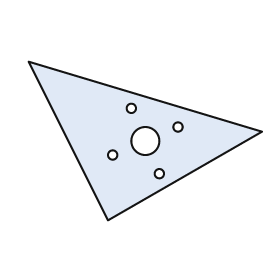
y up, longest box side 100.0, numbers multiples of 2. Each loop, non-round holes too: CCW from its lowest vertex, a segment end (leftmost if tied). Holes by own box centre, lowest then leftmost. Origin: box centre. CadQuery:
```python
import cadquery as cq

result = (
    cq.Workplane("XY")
    .moveTo(-16.0, -34.0)
    .lineTo(50.0, 4.0)
    .lineTo(-50.0, 34.0)
    .close()
    .moveTo(6.0, -14.0)
    .circle(2.0)
    .moveTo(-14.0, -6.0)
    .circle(2.0)
    .moveTo(0.0, 0.0)
    .circle(6.0)
    .moveTo(14.0, 6.0)
    .circle(2.0)
    .moveTo(-6.0, 14.0)
    .circle(2.0)
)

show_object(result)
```